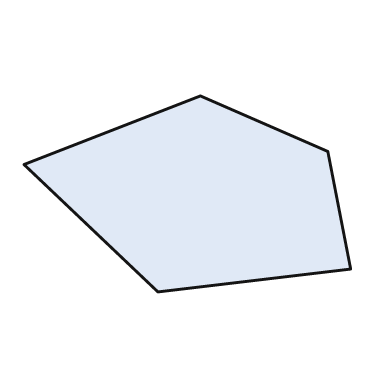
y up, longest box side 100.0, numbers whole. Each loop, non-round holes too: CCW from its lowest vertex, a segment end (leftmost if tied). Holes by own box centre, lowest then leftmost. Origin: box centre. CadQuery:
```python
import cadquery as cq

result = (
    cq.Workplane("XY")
    .moveTo(-9.0, -30.0)
    .lineTo(50.0, -23.0)
    .lineTo(43.0, 13.0)
    .lineTo(4.0, 30.0)
    .lineTo(-50.0, 9.0)
    .close()
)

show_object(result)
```